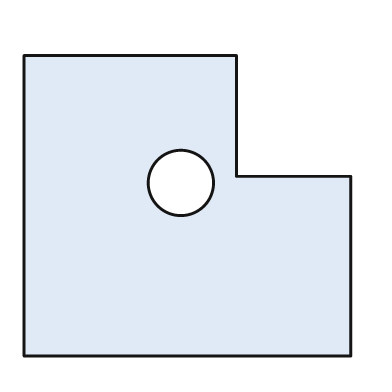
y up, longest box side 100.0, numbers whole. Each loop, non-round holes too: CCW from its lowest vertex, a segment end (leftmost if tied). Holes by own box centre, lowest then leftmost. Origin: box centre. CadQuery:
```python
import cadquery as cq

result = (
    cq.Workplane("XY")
    .moveTo(-50.0, -46.0)
    .lineTo(50.0, -46.0)
    .lineTo(50.0, 9.0)
    .lineTo(15.0, 9.0)
    .lineTo(15.0, 46.0)
    .lineTo(-50.0, 46.0)
    .close()
    .moveTo(-2.0, 7.0)
    .circle(10.0)
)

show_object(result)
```